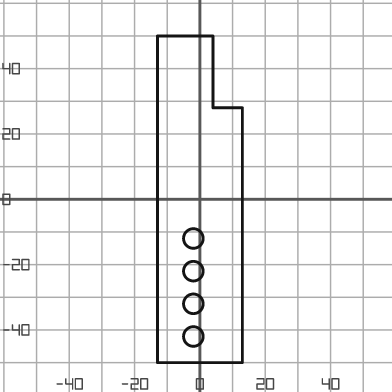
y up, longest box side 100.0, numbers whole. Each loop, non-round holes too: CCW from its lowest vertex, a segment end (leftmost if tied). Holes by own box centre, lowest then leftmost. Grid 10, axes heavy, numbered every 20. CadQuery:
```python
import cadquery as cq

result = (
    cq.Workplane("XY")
    .moveTo(-13.0, -50.0)
    .lineTo(13.0, -50.0)
    .lineTo(13.0, 28.0)
    .lineTo(4.0, 28.0)
    .lineTo(4.0, 50.0)
    .lineTo(-13.0, 50.0)
    .close()
    .moveTo(-2.0, -42.0)
    .circle(3.0)
    .moveTo(-2.0, -32.0)
    .circle(3.0)
    .moveTo(-2.0, -22.0)
    .circle(3.0)
    .moveTo(-2.0, -12.0)
    .circle(3.0)
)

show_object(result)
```